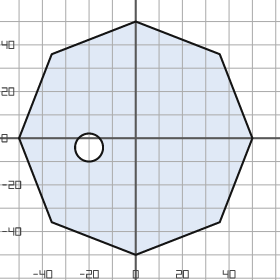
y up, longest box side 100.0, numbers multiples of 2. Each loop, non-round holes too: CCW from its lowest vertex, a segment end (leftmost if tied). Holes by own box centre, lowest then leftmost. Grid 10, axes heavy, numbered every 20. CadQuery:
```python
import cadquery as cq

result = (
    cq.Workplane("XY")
    .moveTo(0.0, -50.0)
    .lineTo(36.0, -36.0)
    .lineTo(50.0, 0.0)
    .lineTo(36.0, 36.0)
    .lineTo(0.0, 50.0)
    .lineTo(-36.0, 36.0)
    .lineTo(-50.0, 0.0)
    .lineTo(-36.0, -36.0)
    .close()
    .moveTo(-20.0, -4.0)
    .circle(6.0)
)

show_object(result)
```